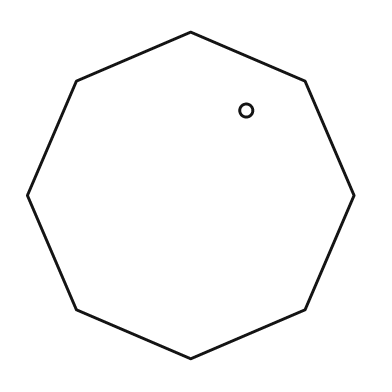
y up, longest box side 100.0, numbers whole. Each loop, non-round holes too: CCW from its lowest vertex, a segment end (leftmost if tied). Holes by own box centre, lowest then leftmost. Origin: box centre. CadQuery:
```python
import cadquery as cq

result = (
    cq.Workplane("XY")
    .moveTo(0.0, -50.0)
    .lineTo(35.0, -35.0)
    .lineTo(50.0, 0.0)
    .lineTo(35.0, 35.0)
    .lineTo(0.0, 50.0)
    .lineTo(-35.0, 35.0)
    .lineTo(-50.0, 0.0)
    .lineTo(-35.0, -35.0)
    .close()
    .moveTo(17.0, 26.0)
    .circle(2.0)
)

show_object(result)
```